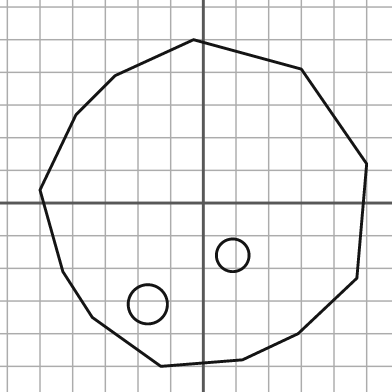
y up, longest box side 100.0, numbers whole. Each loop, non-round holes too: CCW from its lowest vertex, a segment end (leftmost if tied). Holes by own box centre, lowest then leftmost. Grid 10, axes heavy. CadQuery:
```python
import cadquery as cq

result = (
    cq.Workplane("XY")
    .moveTo(-13.0, -50.0)
    .lineTo(12.0, -48.0)
    .lineTo(29.0, -40.0)
    .lineTo(47.0, -23.0)
    .lineTo(50.0, 12.0)
    .lineTo(30.0, 41.0)
    .lineTo(-3.0, 50.0)
    .lineTo(-27.0, 39.0)
    .lineTo(-39.0, 27.0)
    .lineTo(-50.0, 4.0)
    .lineTo(-43.0, -21.0)
    .lineTo(-34.0, -35.0)
    .close()
    .moveTo(-17.0, -31.0)
    .circle(6.0)
    .moveTo(9.0, -16.0)
    .circle(5.0)
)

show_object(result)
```